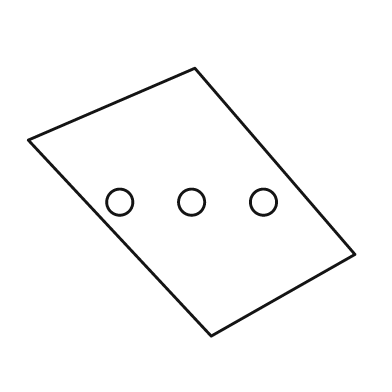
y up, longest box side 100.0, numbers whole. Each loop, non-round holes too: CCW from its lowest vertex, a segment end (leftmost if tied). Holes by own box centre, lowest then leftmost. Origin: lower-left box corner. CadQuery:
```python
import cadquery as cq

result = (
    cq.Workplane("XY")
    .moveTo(56.0, 0.0)
    .lineTo(100.0, 25.0)
    .lineTo(51.0, 82.0)
    .lineTo(0.0, 60.0)
    .close()
    .moveTo(28.0, 41.0)
    .circle(4.0)
    .moveTo(50.0, 41.0)
    .circle(4.0)
    .moveTo(72.0, 41.0)
    .circle(4.0)
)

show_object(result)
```